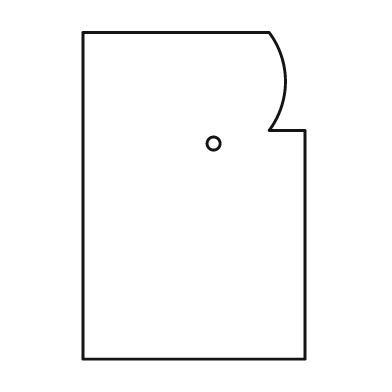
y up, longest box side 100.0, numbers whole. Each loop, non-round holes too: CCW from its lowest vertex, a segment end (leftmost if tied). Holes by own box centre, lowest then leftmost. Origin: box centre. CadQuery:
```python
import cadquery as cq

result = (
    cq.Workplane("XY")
    .moveTo(-34.0, -50.0)
    .lineTo(34.0, -50.0)
    .lineTo(34.0, 20.0)
    .lineTo(23.0, 20.0)
    .threePointArc((28.0, 35.0), (23.0, 50.0))
    .lineTo(-34.0, 50.0)
    .close()
    .moveTo(6.0, 16.0)
    .circle(2.0)
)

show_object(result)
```